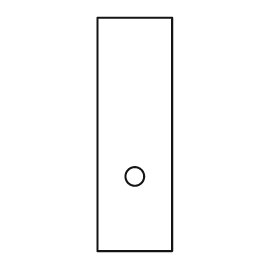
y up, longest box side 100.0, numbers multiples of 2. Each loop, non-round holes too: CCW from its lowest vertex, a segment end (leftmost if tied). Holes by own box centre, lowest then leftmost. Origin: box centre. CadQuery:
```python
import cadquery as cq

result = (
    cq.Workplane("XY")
    .moveTo(-16.0, -50.0)
    .lineTo(16.0, -50.0)
    .lineTo(16.0, 50.0)
    .lineTo(-16.0, 50.0)
    .close()
    .moveTo(0.0, -18.0)
    .circle(4.0)
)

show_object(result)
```